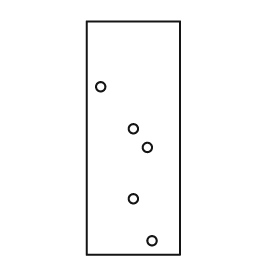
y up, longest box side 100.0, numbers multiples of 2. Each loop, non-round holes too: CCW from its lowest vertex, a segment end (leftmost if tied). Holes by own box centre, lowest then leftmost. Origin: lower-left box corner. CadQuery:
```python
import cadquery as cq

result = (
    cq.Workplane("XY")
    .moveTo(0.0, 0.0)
    .lineTo(40.0, 0.0)
    .lineTo(40.0, 100.0)
    .lineTo(0.0, 100.0)
    .close()
    .moveTo(28.0, 6.0)
    .circle(2.0)
    .moveTo(20.0, 24.0)
    .circle(2.0)
    .moveTo(26.0, 46.0)
    .circle(2.0)
    .moveTo(20.0, 54.0)
    .circle(2.0)
    .moveTo(6.0, 72.0)
    .circle(2.0)
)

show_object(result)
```